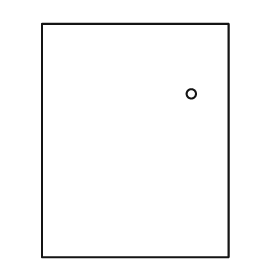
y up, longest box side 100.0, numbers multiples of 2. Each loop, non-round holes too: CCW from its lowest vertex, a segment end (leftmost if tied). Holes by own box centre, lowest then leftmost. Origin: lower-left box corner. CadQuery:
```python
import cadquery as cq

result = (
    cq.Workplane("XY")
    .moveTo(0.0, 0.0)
    .lineTo(80.0, 0.0)
    .lineTo(80.0, 100.0)
    .lineTo(0.0, 100.0)
    .close()
    .moveTo(64.0, 70.0)
    .circle(2.0)
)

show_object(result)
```